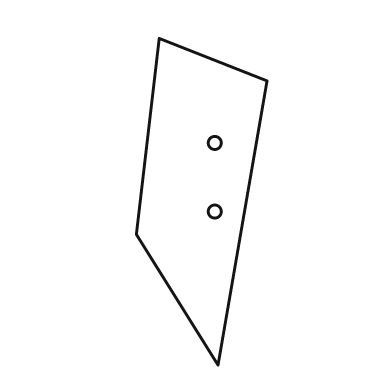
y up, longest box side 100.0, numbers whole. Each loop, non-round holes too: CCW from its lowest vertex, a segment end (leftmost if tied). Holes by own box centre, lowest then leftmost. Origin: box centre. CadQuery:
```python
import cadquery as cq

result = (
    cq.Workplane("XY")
    .moveTo(5.0, -50.0)
    .lineTo(20.0, 37.0)
    .lineTo(-13.0, 50.0)
    .lineTo(-20.0, -10.0)
    .close()
    .moveTo(4.0, -3.0)
    .circle(2.0)
    .moveTo(4.0, 18.0)
    .circle(2.0)
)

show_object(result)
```